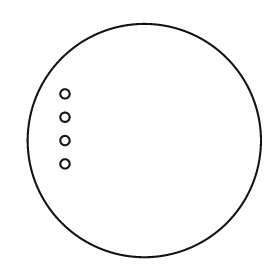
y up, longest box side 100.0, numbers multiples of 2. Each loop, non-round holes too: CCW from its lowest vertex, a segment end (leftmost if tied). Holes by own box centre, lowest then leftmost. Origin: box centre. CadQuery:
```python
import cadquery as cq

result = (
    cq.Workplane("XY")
    .moveTo(0.0, 0.0)
    .circle(50.0)
    .moveTo(-34.0, -10.0)
    .circle(2.0)
    .moveTo(-34.0, 0.0)
    .circle(2.0)
    .moveTo(-34.0, 10.0)
    .circle(2.0)
    .moveTo(-34.0, 20.0)
    .circle(2.0)
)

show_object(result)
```